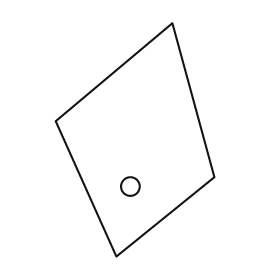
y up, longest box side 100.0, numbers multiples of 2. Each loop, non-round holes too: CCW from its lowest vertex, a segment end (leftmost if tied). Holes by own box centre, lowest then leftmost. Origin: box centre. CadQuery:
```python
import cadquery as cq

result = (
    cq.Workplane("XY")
    .moveTo(-8.0, -50.0)
    .lineTo(34.0, -16.0)
    .lineTo(16.0, 50.0)
    .lineTo(-34.0, 8.0)
    .close()
    .moveTo(-2.0, -20.0)
    .circle(4.0)
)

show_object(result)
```